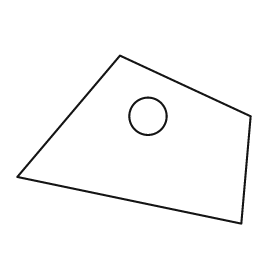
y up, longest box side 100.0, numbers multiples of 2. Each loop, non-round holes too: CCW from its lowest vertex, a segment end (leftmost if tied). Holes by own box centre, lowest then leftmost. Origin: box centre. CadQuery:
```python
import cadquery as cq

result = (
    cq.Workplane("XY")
    .moveTo(46.0, -36.0)
    .lineTo(50.0, 10.0)
    .lineTo(-6.0, 36.0)
    .lineTo(-50.0, -16.0)
    .close()
    .moveTo(6.0, 10.0)
    .circle(8.0)
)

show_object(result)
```